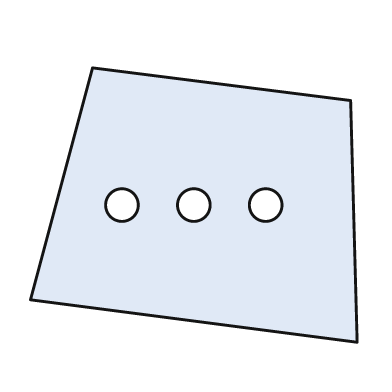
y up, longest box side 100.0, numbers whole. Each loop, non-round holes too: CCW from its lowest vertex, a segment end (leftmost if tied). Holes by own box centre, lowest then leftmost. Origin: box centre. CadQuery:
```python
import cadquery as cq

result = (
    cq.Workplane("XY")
    .moveTo(50.0, -42.0)
    .lineTo(48.0, 32.0)
    .lineTo(-31.0, 42.0)
    .lineTo(-50.0, -29.0)
    .close()
    .moveTo(-22.0, 0.0)
    .circle(5.0)
    .moveTo(0.0, 0.0)
    .circle(5.0)
    .moveTo(22.0, 0.0)
    .circle(5.0)
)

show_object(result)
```